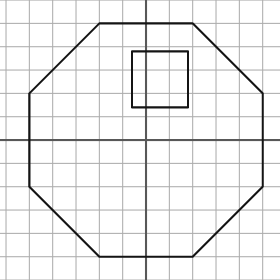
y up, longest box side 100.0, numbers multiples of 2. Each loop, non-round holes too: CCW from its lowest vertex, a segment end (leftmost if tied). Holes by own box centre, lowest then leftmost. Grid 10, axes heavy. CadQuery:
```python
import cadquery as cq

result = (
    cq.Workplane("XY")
    .moveTo(-20.0, -50.0)
    .lineTo(20.0, -50.0)
    .lineTo(50.0, -20.0)
    .lineTo(50.0, 20.0)
    .lineTo(20.0, 50.0)
    .lineTo(-20.0, 50.0)
    .lineTo(-50.0, 20.0)
    .lineTo(-50.0, -20.0)
    .close()
    .moveTo(-6.0, 14.0)
    .lineTo(18.0, 14.0)
    .lineTo(18.0, 38.0)
    .lineTo(-6.0, 38.0)
    .close()
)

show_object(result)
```